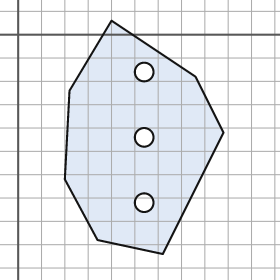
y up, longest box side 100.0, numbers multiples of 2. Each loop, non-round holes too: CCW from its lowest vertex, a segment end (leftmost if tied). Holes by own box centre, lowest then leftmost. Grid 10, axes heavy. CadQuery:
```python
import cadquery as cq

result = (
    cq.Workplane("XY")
    .moveTo(62.0, -94.0)
    .lineTo(88.0, -42.0)
    .lineTo(76.0, -18.0)
    .lineTo(40.0, 6.0)
    .lineTo(22.0, -24.0)
    .lineTo(20.0, -62.0)
    .lineTo(34.0, -88.0)
    .close()
    .moveTo(54.0, -72.0)
    .circle(4.0)
    .moveTo(54.0, -44.0)
    .circle(4.0)
    .moveTo(54.0, -16.0)
    .circle(4.0)
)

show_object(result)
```